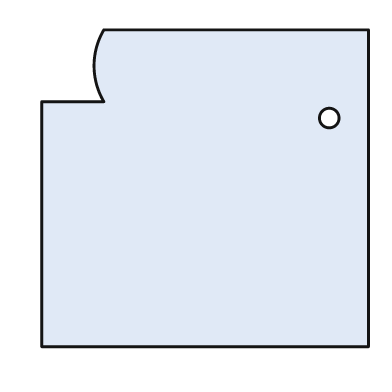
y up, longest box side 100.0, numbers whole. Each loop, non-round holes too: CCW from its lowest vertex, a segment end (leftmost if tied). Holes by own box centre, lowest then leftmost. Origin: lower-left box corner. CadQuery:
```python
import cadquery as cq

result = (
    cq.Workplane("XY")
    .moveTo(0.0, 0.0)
    .lineTo(100.0, 0.0)
    .lineTo(100.0, 97.0)
    .lineTo(19.0, 97.0)
    .threePointArc((16.0, 86.0), (19.0, 75.0))
    .lineTo(0.0, 75.0)
    .close()
    .moveTo(88.0, 70.0)
    .circle(3.0)
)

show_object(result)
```